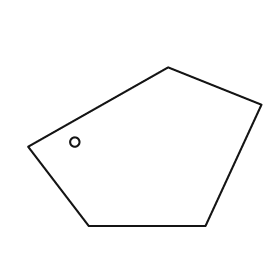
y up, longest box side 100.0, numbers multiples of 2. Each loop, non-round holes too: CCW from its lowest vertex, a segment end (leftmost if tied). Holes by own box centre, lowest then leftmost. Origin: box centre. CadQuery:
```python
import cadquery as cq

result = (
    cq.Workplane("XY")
    .moveTo(-24.0, -34.0)
    .lineTo(26.0, -34.0)
    .lineTo(50.0, 18.0)
    .lineTo(10.0, 34.0)
    .lineTo(-50.0, 0.0)
    .close()
    .moveTo(-30.0, 2.0)
    .circle(2.0)
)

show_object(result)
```